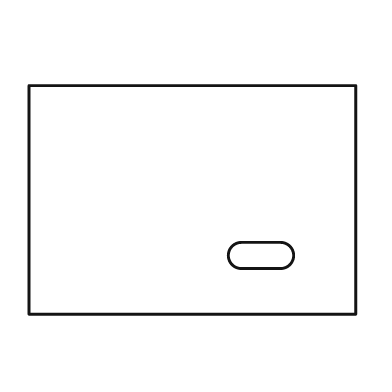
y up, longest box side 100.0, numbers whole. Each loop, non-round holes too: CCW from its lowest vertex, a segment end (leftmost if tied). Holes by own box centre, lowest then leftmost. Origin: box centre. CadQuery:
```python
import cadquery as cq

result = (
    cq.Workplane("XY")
    .moveTo(-50.0, -35.0)
    .lineTo(50.0, -35.0)
    .lineTo(50.0, 35.0)
    .lineTo(-50.0, 35.0)
    .close()
    .moveTo(15.0, -21.0)
    .lineTo(27.0, -21.0)
    .threePointArc((31.0, -17.0), (27.0, -13.0))
    .lineTo(15.0, -13.0)
    .threePointArc((11.0, -17.0), (15.0, -21.0))
    .close()
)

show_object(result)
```